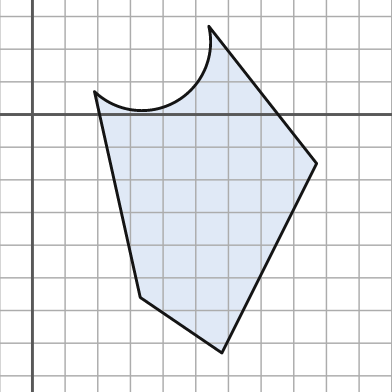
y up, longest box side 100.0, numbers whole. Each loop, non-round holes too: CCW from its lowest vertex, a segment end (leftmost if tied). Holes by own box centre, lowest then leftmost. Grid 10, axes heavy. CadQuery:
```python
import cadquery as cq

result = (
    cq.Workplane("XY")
    .moveTo(58.0, -73.0)
    .lineTo(87.0, -15.0)
    .lineTo(54.0, 27.0)
    .threePointArc((44.0, 4.0), (19.0, 7.0))
    .lineTo(33.0, -56.0)
    .close()
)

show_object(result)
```